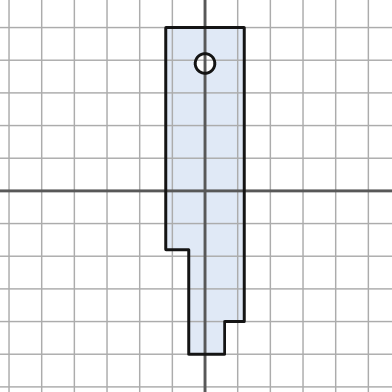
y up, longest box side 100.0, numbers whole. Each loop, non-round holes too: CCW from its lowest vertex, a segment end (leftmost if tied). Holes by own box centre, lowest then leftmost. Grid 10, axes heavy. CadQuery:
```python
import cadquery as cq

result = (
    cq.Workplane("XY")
    .moveTo(-5.0, -50.0)
    .lineTo(6.0, -50.0)
    .lineTo(6.0, -40.0)
    .lineTo(12.0, -40.0)
    .lineTo(12.0, 50.0)
    .lineTo(-12.0, 50.0)
    .lineTo(-12.0, -18.0)
    .lineTo(-5.0, -18.0)
    .close()
    .moveTo(0.0, 39.0)
    .circle(3.0)
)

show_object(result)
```